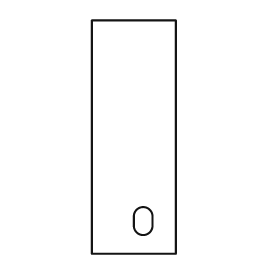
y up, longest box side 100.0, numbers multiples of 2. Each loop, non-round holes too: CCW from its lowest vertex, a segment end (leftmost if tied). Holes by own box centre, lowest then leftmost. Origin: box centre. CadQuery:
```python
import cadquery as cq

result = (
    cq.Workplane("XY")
    .moveTo(-18.0, -50.0)
    .lineTo(18.0, -50.0)
    .lineTo(18.0, 50.0)
    .lineTo(-18.0, 50.0)
    .close()
    .moveTo(0.0, -38.0)
    .threePointArc((4.0, -42.0), (8.0, -38.0))
    .lineTo(8.0, -34.0)
    .threePointArc((4.0, -30.0), (0.0, -34.0))
    .close()
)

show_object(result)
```